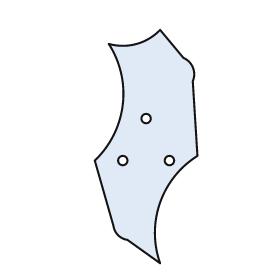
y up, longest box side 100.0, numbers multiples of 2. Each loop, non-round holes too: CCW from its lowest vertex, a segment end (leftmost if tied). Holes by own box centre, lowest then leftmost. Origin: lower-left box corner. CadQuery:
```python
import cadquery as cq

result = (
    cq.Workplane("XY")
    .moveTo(28.0, 0.0)
    .threePointArc((28.0, 26.0), (44.0, 46.0))
    .lineTo(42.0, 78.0)
    .threePointArc((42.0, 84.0), (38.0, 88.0))
    .lineTo(28.0, 100.0)
    .threePointArc((18.0, 94.0), (6.0, 94.0))
    .threePointArc((12.0, 68.0), (0.0, 44.0))
    .lineTo(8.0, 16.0)
    .threePointArc((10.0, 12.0), (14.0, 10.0))
    .close()
    .moveTo(12.0, 44.0)
    .circle(2.0)
    .moveTo(32.0, 44.0)
    .circle(2.0)
    .moveTo(22.0, 62.0)
    .circle(2.0)
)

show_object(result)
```